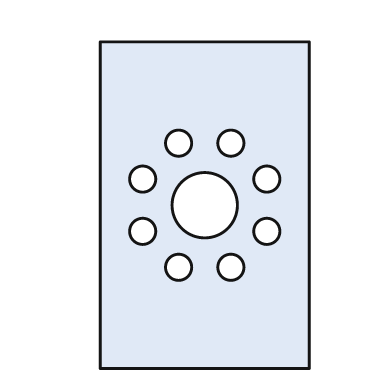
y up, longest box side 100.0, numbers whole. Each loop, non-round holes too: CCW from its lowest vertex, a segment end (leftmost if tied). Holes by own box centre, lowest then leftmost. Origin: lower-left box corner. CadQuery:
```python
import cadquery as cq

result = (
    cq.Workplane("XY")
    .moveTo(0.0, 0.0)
    .lineTo(64.0, 0.0)
    .lineTo(64.0, 100.0)
    .lineTo(0.0, 100.0)
    .close()
    .moveTo(24.0, 31.0)
    .circle(4.0)
    .moveTo(40.0, 31.0)
    .circle(4.0)
    .moveTo(13.0, 42.0)
    .circle(4.0)
    .moveTo(51.0, 42.0)
    .circle(4.0)
    .moveTo(32.0, 50.0)
    .circle(10.0)
    .moveTo(13.0, 58.0)
    .circle(4.0)
    .moveTo(51.0, 58.0)
    .circle(4.0)
    .moveTo(24.0, 69.0)
    .circle(4.0)
    .moveTo(40.0, 69.0)
    .circle(4.0)
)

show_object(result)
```